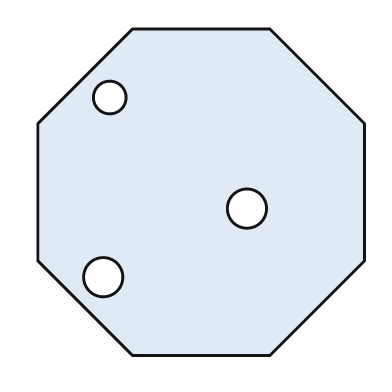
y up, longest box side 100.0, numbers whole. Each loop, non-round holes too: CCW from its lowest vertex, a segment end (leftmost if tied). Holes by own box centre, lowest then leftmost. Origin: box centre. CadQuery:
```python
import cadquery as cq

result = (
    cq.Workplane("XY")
    .moveTo(-21.0, -50.0)
    .lineTo(21.0, -50.0)
    .lineTo(50.0, -21.0)
    .lineTo(50.0, 21.0)
    .lineTo(21.0, 50.0)
    .lineTo(-21.0, 50.0)
    .lineTo(-50.0, 21.0)
    .lineTo(-50.0, -21.0)
    .close()
    .moveTo(-30.0, -26.0)
    .circle(6.0)
    .moveTo(14.0, -5.0)
    .circle(6.0)
    .moveTo(-28.0, 29.0)
    .circle(5.0)
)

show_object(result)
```